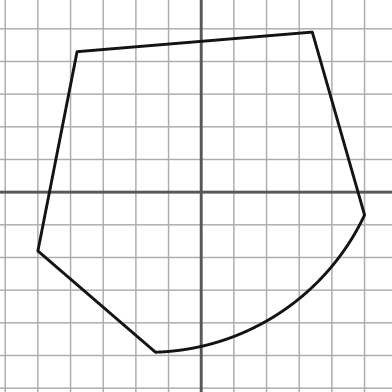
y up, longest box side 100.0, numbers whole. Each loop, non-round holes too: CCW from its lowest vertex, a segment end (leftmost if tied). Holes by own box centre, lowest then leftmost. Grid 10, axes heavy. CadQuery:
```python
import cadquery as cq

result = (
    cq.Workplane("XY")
    .moveTo(-14.0, -49.0)
    .threePointArc((24.0, -37.0), (50.0, -7.0))
    .lineTo(34.0, 49.0)
    .lineTo(-38.0, 43.0)
    .lineTo(-50.0, -18.0)
    .close()
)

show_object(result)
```